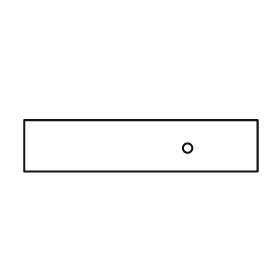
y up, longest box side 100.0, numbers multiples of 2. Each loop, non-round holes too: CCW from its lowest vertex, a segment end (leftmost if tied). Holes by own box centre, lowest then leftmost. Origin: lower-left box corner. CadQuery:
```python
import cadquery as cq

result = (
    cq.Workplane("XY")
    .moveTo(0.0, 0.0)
    .lineTo(100.0, 0.0)
    .lineTo(100.0, 22.0)
    .lineTo(0.0, 22.0)
    .close()
    .moveTo(70.0, 10.0)
    .circle(2.0)
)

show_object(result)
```